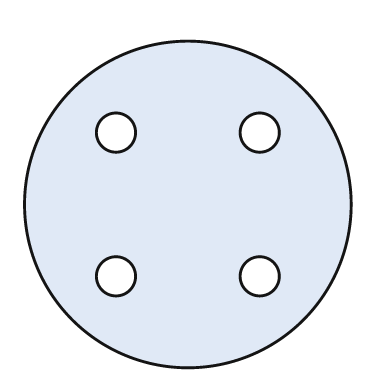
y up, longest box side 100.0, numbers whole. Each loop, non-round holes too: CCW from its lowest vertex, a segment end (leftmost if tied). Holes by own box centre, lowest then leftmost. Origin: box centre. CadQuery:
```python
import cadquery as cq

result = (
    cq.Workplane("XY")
    .moveTo(0.0, 0.0)
    .circle(50.0)
    .moveTo(-22.0, -22.0)
    .circle(6.0)
    .moveTo(22.0, -22.0)
    .circle(6.0)
    .moveTo(-22.0, 22.0)
    .circle(6.0)
    .moveTo(22.0, 22.0)
    .circle(6.0)
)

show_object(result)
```